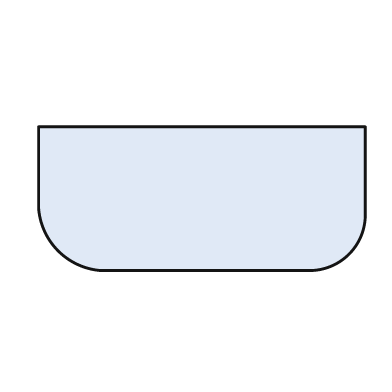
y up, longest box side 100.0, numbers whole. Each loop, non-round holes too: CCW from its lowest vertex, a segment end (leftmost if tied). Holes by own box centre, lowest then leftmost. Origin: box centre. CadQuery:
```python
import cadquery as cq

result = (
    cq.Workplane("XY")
    .moveTo(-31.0, -22.0)
    .lineTo(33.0, -22.0)
    .threePointArc((45.0, -17.0), (50.0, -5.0))
    .lineTo(50.0, 22.0)
    .lineTo(-50.0, 22.0)
    .lineTo(-50.0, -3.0)
    .threePointArc((-44.0, -16.0), (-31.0, -22.0))
    .close()
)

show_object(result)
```